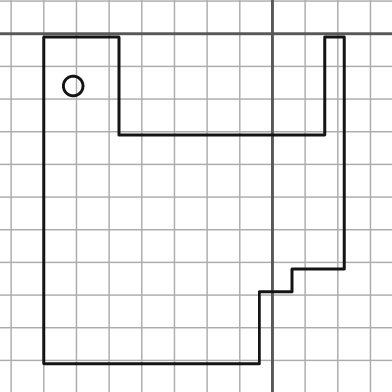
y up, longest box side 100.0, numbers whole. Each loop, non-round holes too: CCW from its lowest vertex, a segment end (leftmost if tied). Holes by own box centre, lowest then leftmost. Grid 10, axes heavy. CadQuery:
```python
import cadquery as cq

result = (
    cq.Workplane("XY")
    .moveTo(-70.0, -101.0)
    .lineTo(-4.0, -101.0)
    .lineTo(-4.0, -79.0)
    .lineTo(6.0, -79.0)
    .lineTo(6.0, -72.0)
    .lineTo(22.0, -72.0)
    .lineTo(22.0, -1.0)
    .lineTo(16.0, -1.0)
    .lineTo(16.0, -31.0)
    .lineTo(-47.0, -31.0)
    .lineTo(-47.0, -1.0)
    .lineTo(-70.0, -1.0)
    .close()
    .moveTo(-61.0, -16.0)
    .circle(3.0)
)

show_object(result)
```